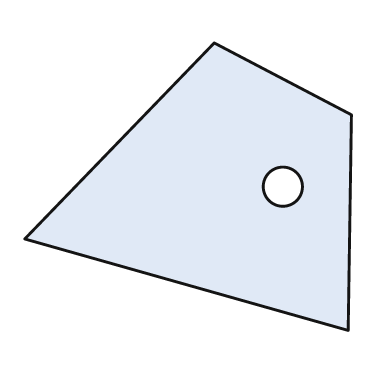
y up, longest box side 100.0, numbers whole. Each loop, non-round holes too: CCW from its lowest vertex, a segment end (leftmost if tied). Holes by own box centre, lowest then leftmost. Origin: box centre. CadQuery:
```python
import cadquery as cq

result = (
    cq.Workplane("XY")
    .moveTo(49.0, -44.0)
    .lineTo(50.0, 22.0)
    .lineTo(8.0, 44.0)
    .lineTo(-50.0, -16.0)
    .close()
    .moveTo(29.0, 0.0)
    .circle(6.0)
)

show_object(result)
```